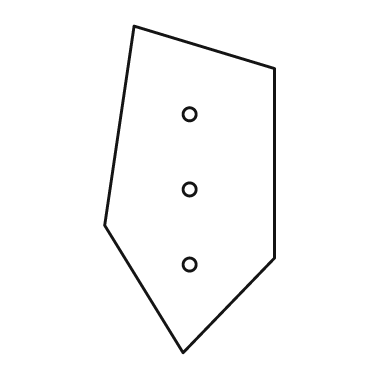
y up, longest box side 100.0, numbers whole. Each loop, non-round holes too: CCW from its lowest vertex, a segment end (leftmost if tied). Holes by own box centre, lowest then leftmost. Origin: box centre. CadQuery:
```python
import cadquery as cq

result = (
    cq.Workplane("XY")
    .moveTo(-2.0, -50.0)
    .lineTo(26.0, -21.0)
    .lineTo(26.0, 37.0)
    .lineTo(-17.0, 50.0)
    .lineTo(-26.0, -11.0)
    .close()
    .moveTo(0.0, -23.0)
    .circle(2.0)
    .moveTo(0.0, 0.0)
    .circle(2.0)
    .moveTo(0.0, 23.0)
    .circle(2.0)
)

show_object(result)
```